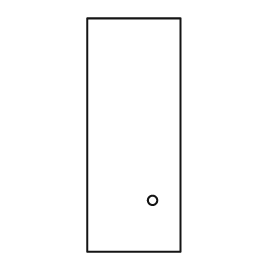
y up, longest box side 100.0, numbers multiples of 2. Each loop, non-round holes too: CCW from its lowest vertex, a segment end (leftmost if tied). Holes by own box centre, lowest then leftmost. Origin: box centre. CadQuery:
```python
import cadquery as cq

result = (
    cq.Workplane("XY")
    .moveTo(-20.0, -50.0)
    .lineTo(20.0, -50.0)
    .lineTo(20.0, 50.0)
    .lineTo(-20.0, 50.0)
    .close()
    .moveTo(8.0, -28.0)
    .circle(2.0)
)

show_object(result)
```